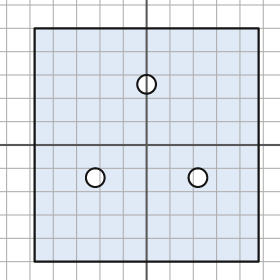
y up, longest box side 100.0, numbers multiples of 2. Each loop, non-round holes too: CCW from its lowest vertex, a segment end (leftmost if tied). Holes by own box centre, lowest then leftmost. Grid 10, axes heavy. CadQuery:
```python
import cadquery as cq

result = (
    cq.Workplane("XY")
    .moveTo(-48.0, -50.0)
    .lineTo(48.0, -50.0)
    .lineTo(48.0, 50.0)
    .lineTo(-48.0, 50.0)
    .close()
    .moveTo(-22.0, -14.0)
    .circle(4.0)
    .moveTo(22.0, -14.0)
    .circle(4.0)
    .moveTo(0.0, 26.0)
    .circle(4.0)
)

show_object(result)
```